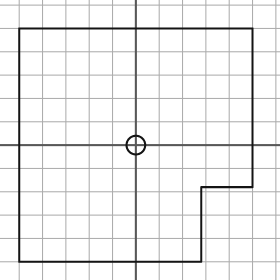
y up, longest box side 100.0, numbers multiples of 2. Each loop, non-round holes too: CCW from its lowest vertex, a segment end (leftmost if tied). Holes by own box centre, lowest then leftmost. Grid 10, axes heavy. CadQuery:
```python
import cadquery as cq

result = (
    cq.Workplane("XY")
    .moveTo(-50.0, -50.0)
    .lineTo(28.0, -50.0)
    .lineTo(28.0, -18.0)
    .lineTo(50.0, -18.0)
    .lineTo(50.0, 50.0)
    .lineTo(-50.0, 50.0)
    .close()
    .moveTo(0.0, 0.0)
    .circle(4.0)
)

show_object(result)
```